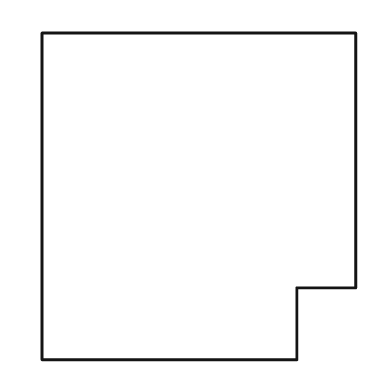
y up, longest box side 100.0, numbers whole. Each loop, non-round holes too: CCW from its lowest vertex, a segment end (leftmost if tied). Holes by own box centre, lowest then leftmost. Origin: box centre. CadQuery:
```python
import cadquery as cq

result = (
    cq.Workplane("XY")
    .moveTo(-48.0, -50.0)
    .lineTo(30.0, -50.0)
    .lineTo(30.0, -28.0)
    .lineTo(48.0, -28.0)
    .lineTo(48.0, 50.0)
    .lineTo(-48.0, 50.0)
    .close()
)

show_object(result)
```